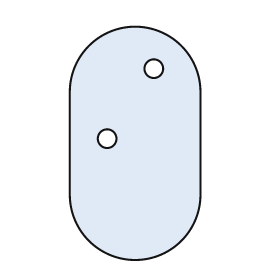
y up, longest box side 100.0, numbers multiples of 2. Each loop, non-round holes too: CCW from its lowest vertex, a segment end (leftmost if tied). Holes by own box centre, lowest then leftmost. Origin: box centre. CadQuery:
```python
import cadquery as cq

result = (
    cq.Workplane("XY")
    .moveTo(-28.0, -22.0)
    .threePointArc((0.0, -50.0), (28.0, -22.0))
    .lineTo(28.0, 22.0)
    .threePointArc((0.0, 50.0), (-28.0, 22.0))
    .close()
    .moveTo(-12.0, 2.0)
    .circle(4.0)
    .moveTo(8.0, 32.0)
    .circle(4.0)
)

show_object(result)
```